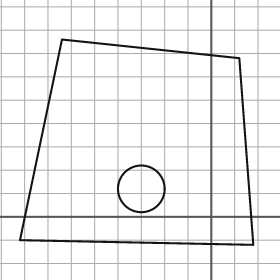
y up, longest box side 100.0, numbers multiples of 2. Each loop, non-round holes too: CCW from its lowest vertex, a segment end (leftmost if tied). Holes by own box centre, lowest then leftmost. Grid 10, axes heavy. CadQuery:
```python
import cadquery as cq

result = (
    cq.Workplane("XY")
    .moveTo(18.0, -12.0)
    .lineTo(12.0, 68.0)
    .lineTo(-64.0, 76.0)
    .lineTo(-82.0, -10.0)
    .close()
    .moveTo(-30.0, 12.0)
    .circle(10.0)
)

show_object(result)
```